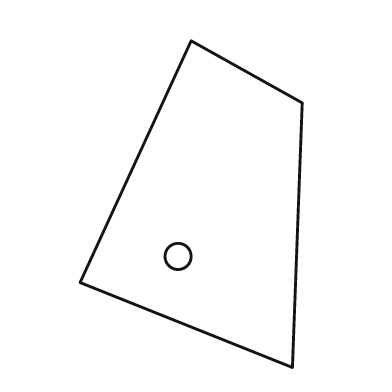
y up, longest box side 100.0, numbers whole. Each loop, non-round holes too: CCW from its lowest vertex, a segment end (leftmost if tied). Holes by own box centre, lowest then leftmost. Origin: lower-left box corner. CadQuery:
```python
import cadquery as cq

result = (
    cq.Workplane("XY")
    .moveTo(65.0, 0.0)
    .lineTo(68.0, 81.0)
    .lineTo(34.0, 100.0)
    .lineTo(0.0, 26.0)
    .close()
    .moveTo(30.0, 34.0)
    .circle(4.0)
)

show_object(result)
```